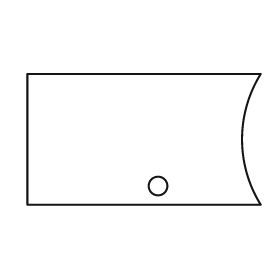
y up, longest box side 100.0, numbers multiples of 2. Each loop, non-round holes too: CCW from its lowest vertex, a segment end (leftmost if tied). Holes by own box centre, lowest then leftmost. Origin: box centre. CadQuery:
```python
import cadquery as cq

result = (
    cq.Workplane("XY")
    .moveTo(-50.0, -28.0)
    .lineTo(50.0, -28.0)
    .threePointArc((42.0, 0.0), (50.0, 28.0))
    .lineTo(-50.0, 28.0)
    .close()
    .moveTo(6.0, -20.0)
    .circle(4.0)
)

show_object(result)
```